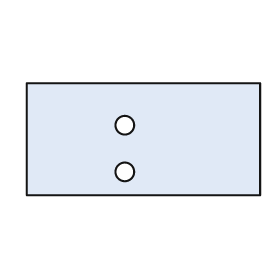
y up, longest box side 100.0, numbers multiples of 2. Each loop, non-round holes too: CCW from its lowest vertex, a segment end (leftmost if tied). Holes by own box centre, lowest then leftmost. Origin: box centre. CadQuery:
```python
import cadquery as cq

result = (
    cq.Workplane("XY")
    .moveTo(-50.0, -24.0)
    .lineTo(50.0, -24.0)
    .lineTo(50.0, 24.0)
    .lineTo(-50.0, 24.0)
    .close()
    .moveTo(-8.0, -14.0)
    .circle(4.0)
    .moveTo(-8.0, 6.0)
    .circle(4.0)
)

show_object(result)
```